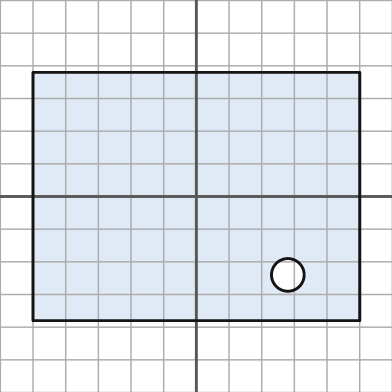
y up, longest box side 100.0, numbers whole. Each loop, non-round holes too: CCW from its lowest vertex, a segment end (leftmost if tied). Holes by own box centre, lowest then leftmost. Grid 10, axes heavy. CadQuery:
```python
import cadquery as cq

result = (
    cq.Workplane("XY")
    .moveTo(-50.0, -38.0)
    .lineTo(50.0, -38.0)
    .lineTo(50.0, 38.0)
    .lineTo(-50.0, 38.0)
    .close()
    .moveTo(28.0, -24.0)
    .circle(5.0)
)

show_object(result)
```